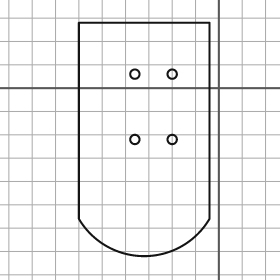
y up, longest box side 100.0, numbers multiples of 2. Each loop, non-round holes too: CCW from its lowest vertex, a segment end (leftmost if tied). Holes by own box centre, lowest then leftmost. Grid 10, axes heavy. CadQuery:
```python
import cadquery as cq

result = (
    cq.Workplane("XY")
    .moveTo(-60.0, -56.0)
    .threePointArc((-32.0, -72.0), (-4.0, -56.0))
    .lineTo(-4.0, 28.0)
    .lineTo(-60.0, 28.0)
    .close()
    .moveTo(-36.0, -22.0)
    .circle(2.0)
    .moveTo(-20.0, -22.0)
    .circle(2.0)
    .moveTo(-36.0, 6.0)
    .circle(2.0)
    .moveTo(-20.0, 6.0)
    .circle(2.0)
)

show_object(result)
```